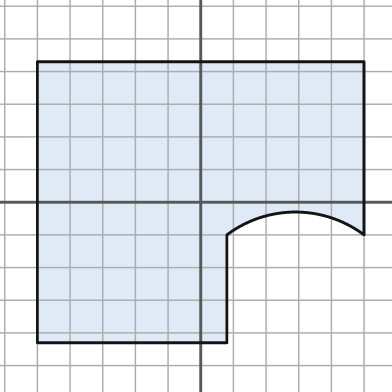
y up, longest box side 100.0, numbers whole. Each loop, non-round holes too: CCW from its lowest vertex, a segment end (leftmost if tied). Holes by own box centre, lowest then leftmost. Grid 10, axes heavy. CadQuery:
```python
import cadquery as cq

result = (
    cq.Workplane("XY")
    .moveTo(-50.0, -43.0)
    .lineTo(8.0, -43.0)
    .lineTo(8.0, -10.0)
    .threePointArc((29.0, -3.0), (50.0, -10.0))
    .lineTo(50.0, 43.0)
    .lineTo(-50.0, 43.0)
    .close()
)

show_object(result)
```